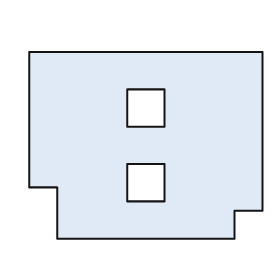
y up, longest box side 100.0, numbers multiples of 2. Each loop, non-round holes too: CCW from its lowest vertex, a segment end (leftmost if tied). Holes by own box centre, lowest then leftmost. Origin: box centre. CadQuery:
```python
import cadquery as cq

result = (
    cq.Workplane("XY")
    .moveTo(-38.0, -40.0)
    .lineTo(38.0, -40.0)
    .lineTo(38.0, -28.0)
    .lineTo(50.0, -28.0)
    .lineTo(50.0, 40.0)
    .lineTo(-50.0, 40.0)
    .lineTo(-50.0, -18.0)
    .lineTo(-38.0, -18.0)
    .close()
    .moveTo(-8.0, -24.0)
    .lineTo(8.0, -24.0)
    .lineTo(8.0, -8.0)
    .lineTo(-8.0, -8.0)
    .close()
    .moveTo(-8.0, 8.0)
    .lineTo(8.0, 8.0)
    .lineTo(8.0, 24.0)
    .lineTo(-8.0, 24.0)
    .close()
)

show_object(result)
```